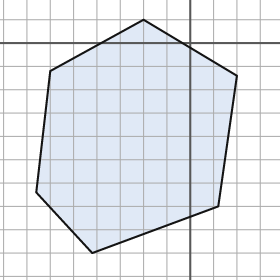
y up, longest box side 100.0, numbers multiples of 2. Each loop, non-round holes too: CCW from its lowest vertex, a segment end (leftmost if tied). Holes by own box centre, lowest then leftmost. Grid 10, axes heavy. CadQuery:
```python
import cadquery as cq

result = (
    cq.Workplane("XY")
    .moveTo(-42.0, -90.0)
    .lineTo(12.0, -70.0)
    .lineTo(20.0, -14.0)
    .lineTo(-20.0, 10.0)
    .lineTo(-60.0, -12.0)
    .lineTo(-66.0, -64.0)
    .close()
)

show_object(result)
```